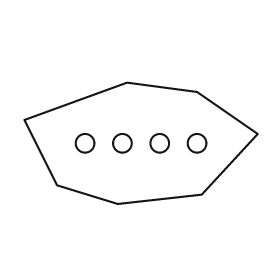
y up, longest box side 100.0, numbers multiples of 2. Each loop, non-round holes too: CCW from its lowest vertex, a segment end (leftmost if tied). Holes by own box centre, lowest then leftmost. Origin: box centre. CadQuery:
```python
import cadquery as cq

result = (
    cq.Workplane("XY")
    .moveTo(-10.0, -26.0)
    .lineTo(26.0, -22.0)
    .lineTo(50.0, 4.0)
    .lineTo(24.0, 22.0)
    .lineTo(-6.0, 26.0)
    .lineTo(-50.0, 10.0)
    .lineTo(-36.0, -18.0)
    .close()
    .moveTo(-24.0, 0.0)
    .circle(4.0)
    .moveTo(-8.0, 0.0)
    .circle(4.0)
    .moveTo(8.0, 0.0)
    .circle(4.0)
    .moveTo(24.0, 0.0)
    .circle(4.0)
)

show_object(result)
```